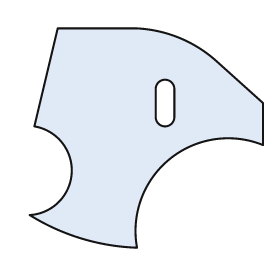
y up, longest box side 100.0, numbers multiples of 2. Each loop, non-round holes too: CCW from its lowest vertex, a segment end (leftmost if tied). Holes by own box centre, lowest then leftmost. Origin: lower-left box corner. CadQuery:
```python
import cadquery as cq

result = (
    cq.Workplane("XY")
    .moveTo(46.0, 0.0)
    .threePointArc((60.0, 38.0), (100.0, 44.0))
    .lineTo(100.0, 62.0)
    .lineTo(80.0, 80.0)
    .threePointArc((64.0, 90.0), (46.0, 94.0))
    .lineTo(12.0, 94.0)
    .lineTo(2.0, 52.0)
    .threePointArc((18.0, 32.0), (0.0, 14.0))
    .threePointArc((22.0, 4.0), (46.0, 0.0))
    .close()
    .moveTo(54.0, 56.0)
    .threePointArc((58.0, 52.0), (62.0, 56.0))
    .lineTo(62.0, 68.0)
    .threePointArc((58.0, 72.0), (54.0, 68.0))
    .close()
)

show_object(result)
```